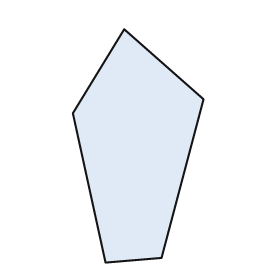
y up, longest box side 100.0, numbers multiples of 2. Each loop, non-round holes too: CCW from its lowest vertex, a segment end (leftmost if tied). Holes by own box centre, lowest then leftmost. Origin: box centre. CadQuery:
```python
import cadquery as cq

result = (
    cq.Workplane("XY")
    .moveTo(-14.0, -50.0)
    .lineTo(10.0, -48.0)
    .lineTo(28.0, 20.0)
    .lineTo(-6.0, 50.0)
    .lineTo(-28.0, 14.0)
    .close()
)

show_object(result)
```